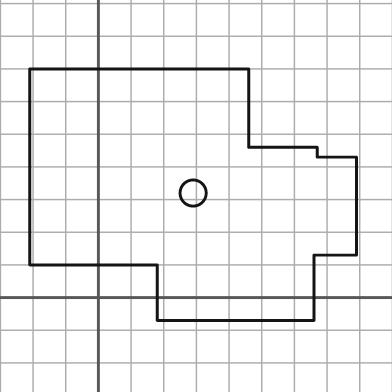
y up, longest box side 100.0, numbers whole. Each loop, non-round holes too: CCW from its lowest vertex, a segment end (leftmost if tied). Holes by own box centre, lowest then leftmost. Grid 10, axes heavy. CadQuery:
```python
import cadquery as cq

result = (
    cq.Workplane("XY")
    .moveTo(18.0, -7.0)
    .lineTo(66.0, -7.0)
    .lineTo(66.0, 13.0)
    .lineTo(79.0, 13.0)
    .lineTo(79.0, 43.0)
    .lineTo(67.0, 43.0)
    .lineTo(67.0, 46.0)
    .lineTo(46.0, 46.0)
    .lineTo(46.0, 70.0)
    .lineTo(-21.0, 70.0)
    .lineTo(-21.0, 10.0)
    .lineTo(18.0, 10.0)
    .close()
    .moveTo(29.0, 32.0)
    .circle(4.0)
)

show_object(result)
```